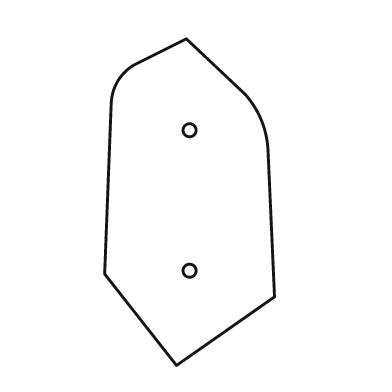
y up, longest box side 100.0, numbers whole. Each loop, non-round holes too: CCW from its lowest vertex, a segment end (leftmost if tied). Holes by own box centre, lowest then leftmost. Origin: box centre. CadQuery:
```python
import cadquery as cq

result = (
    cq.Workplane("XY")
    .moveTo(-4.0, -50.0)
    .lineTo(26.0, -29.0)
    .lineTo(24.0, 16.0)
    .threePointArc((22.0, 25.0), (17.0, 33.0))
    .lineTo(-1.0, 50.0)
    .lineTo(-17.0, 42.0)
    .threePointArc((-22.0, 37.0), (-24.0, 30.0))
    .lineTo(-26.0, -22.0)
    .close()
    .moveTo(0.0, -21.0)
    .circle(2.0)
    .moveTo(0.0, 22.0)
    .circle(2.0)
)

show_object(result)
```